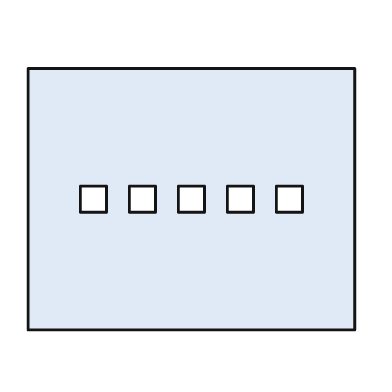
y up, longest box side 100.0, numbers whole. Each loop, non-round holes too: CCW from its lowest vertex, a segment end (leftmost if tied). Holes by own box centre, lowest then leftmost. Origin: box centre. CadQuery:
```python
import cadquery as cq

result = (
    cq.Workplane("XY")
    .moveTo(-50.0, -40.0)
    .lineTo(50.0, -40.0)
    .lineTo(50.0, 40.0)
    .lineTo(-50.0, 40.0)
    .close()
    .moveTo(-34.0, -4.0)
    .lineTo(-26.0, -4.0)
    .lineTo(-26.0, 4.0)
    .lineTo(-34.0, 4.0)
    .close()
    .moveTo(-19.0, -4.0)
    .lineTo(-11.0, -4.0)
    .lineTo(-11.0, 4.0)
    .lineTo(-19.0, 4.0)
    .close()
    .moveTo(-4.0, -4.0)
    .lineTo(4.0, -4.0)
    .lineTo(4.0, 4.0)
    .lineTo(-4.0, 4.0)
    .close()
    .moveTo(11.0, -4.0)
    .lineTo(19.0, -4.0)
    .lineTo(19.0, 4.0)
    .lineTo(11.0, 4.0)
    .close()
    .moveTo(26.0, -4.0)
    .lineTo(34.0, -4.0)
    .lineTo(34.0, 4.0)
    .lineTo(26.0, 4.0)
    .close()
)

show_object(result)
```